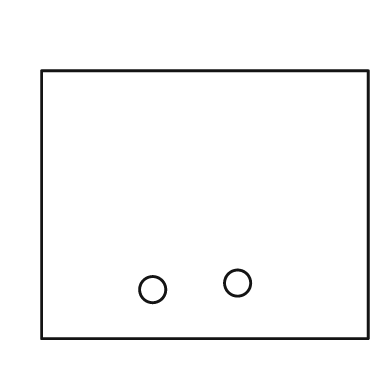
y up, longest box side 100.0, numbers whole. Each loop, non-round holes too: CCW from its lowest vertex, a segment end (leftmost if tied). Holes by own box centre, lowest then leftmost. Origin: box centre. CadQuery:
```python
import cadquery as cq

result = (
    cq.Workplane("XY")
    .moveTo(-50.0, -41.0)
    .lineTo(50.0, -41.0)
    .lineTo(50.0, 41.0)
    .lineTo(-50.0, 41.0)
    .close()
    .moveTo(-16.0, -26.0)
    .circle(4.0)
    .moveTo(10.0, -24.0)
    .circle(4.0)
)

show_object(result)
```